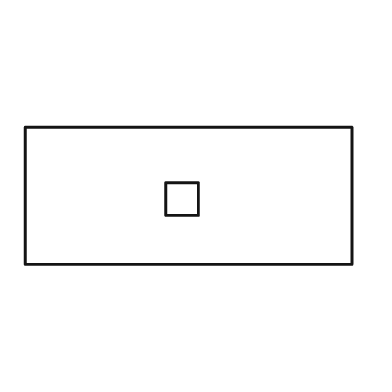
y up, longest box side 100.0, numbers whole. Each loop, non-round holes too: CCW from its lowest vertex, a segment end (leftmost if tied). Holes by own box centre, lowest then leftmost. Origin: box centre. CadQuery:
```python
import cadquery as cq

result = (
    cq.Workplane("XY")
    .moveTo(-50.0, -21.0)
    .lineTo(50.0, -21.0)
    .lineTo(50.0, 21.0)
    .lineTo(-50.0, 21.0)
    .close()
    .moveTo(-7.0, -6.0)
    .lineTo(3.0, -6.0)
    .lineTo(3.0, 4.0)
    .lineTo(-7.0, 4.0)
    .close()
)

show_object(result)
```